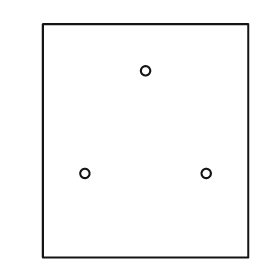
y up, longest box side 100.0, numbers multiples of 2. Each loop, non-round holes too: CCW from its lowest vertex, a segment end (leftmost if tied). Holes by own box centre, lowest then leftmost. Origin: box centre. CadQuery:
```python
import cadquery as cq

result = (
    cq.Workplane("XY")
    .moveTo(-44.0, -50.0)
    .lineTo(44.0, -50.0)
    .lineTo(44.0, 50.0)
    .lineTo(-44.0, 50.0)
    .close()
    .moveTo(-26.0, -14.0)
    .circle(2.0)
    .moveTo(26.0, -14.0)
    .circle(2.0)
    .moveTo(0.0, 30.0)
    .circle(2.0)
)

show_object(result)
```